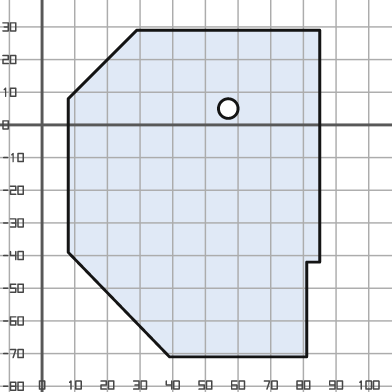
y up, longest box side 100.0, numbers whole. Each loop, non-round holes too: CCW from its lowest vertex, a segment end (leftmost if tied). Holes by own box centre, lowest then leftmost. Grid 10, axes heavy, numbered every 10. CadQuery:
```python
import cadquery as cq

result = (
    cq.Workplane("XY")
    .moveTo(39.0, -71.0)
    .lineTo(81.0, -71.0)
    .lineTo(81.0, -42.0)
    .lineTo(85.0, -42.0)
    .lineTo(85.0, 29.0)
    .lineTo(29.0, 29.0)
    .lineTo(8.0, 8.0)
    .lineTo(8.0, -39.0)
    .close()
    .moveTo(57.0, 5.0)
    .circle(3.0)
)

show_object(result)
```